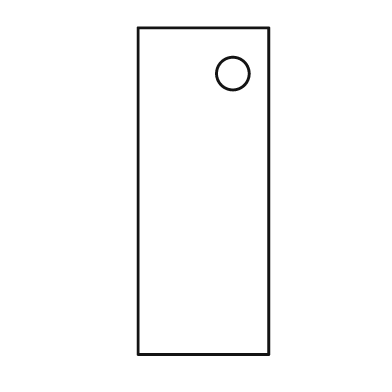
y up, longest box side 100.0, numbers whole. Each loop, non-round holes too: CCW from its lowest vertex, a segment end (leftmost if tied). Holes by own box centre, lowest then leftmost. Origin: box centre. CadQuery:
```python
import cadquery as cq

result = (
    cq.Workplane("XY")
    .moveTo(-20.0, -50.0)
    .lineTo(20.0, -50.0)
    .lineTo(20.0, 50.0)
    .lineTo(-20.0, 50.0)
    .close()
    .moveTo(9.0, 36.0)
    .circle(5.0)
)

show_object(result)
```